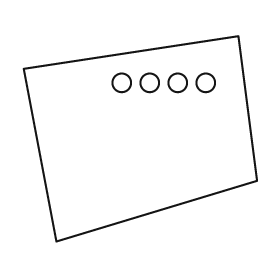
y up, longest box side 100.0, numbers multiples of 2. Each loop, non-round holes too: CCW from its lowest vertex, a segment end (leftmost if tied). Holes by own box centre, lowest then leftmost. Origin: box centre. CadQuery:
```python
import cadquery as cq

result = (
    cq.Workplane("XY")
    .moveTo(-36.0, -44.0)
    .lineTo(50.0, -18.0)
    .lineTo(42.0, 44.0)
    .lineTo(-50.0, 30.0)
    .close()
    .moveTo(-8.0, 24.0)
    .circle(4.0)
    .moveTo(4.0, 24.0)
    .circle(4.0)
    .moveTo(16.0, 24.0)
    .circle(4.0)
    .moveTo(28.0, 24.0)
    .circle(4.0)
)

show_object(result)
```